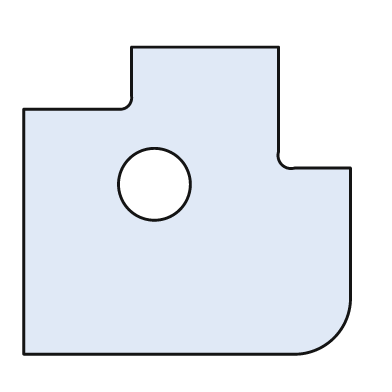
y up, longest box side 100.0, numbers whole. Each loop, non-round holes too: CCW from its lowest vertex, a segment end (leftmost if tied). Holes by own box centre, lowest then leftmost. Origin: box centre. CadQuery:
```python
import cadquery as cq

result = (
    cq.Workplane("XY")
    .moveTo(-50.0, -47.0)
    .lineTo(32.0, -47.0)
    .threePointArc((45.0, -42.0), (50.0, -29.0))
    .lineTo(50.0, 10.0)
    .lineTo(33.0, 10.0)
    .threePointArc((29.0, 11.0), (28.0, 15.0))
    .lineTo(28.0, 47.0)
    .lineTo(-17.0, 47.0)
    .lineTo(-17.0, 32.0)
    .threePointArc((-18.0, 29.0), (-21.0, 28.0))
    .lineTo(-50.0, 28.0)
    .close()
    .moveTo(-10.0, 5.0)
    .circle(11.0)
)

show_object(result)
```